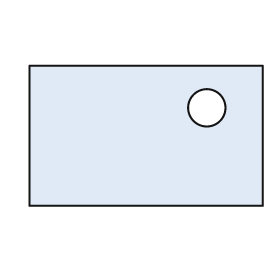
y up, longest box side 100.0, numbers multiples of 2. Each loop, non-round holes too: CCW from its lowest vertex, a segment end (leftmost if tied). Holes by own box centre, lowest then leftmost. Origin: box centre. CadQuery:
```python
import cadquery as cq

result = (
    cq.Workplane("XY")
    .moveTo(-50.0, -30.0)
    .lineTo(50.0, -30.0)
    .lineTo(50.0, 30.0)
    .lineTo(-50.0, 30.0)
    .close()
    .moveTo(26.0, 12.0)
    .circle(8.0)
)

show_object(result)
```